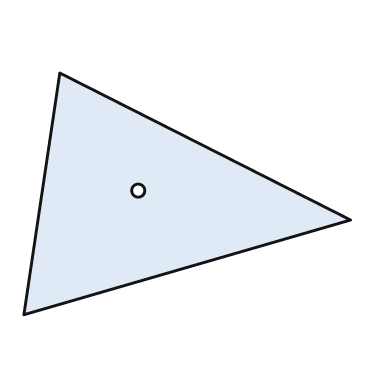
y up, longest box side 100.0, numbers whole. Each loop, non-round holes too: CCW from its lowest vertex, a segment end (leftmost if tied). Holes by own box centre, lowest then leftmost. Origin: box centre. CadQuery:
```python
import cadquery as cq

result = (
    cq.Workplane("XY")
    .moveTo(-50.0, -37.0)
    .lineTo(50.0, -8.0)
    .lineTo(-39.0, 37.0)
    .close()
    .moveTo(-15.0, 1.0)
    .circle(2.0)
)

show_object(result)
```